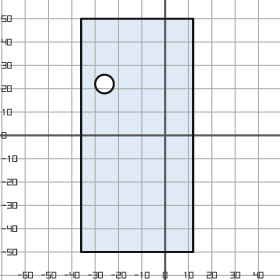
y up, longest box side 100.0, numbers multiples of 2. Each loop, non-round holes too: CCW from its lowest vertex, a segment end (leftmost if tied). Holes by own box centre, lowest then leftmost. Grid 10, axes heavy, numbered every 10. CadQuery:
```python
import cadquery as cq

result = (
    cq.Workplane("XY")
    .moveTo(-36.0, -50.0)
    .lineTo(12.0, -50.0)
    .lineTo(12.0, 50.0)
    .lineTo(-36.0, 50.0)
    .close()
    .moveTo(-26.0, 22.0)
    .circle(4.0)
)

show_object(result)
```